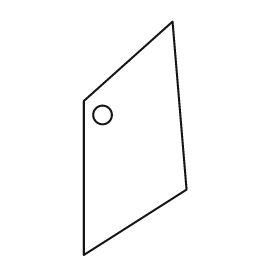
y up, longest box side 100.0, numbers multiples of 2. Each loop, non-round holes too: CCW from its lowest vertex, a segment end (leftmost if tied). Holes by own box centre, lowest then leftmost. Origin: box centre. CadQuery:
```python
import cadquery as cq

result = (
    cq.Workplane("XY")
    .moveTo(-22.0, -50.0)
    .lineTo(22.0, -22.0)
    .lineTo(16.0, 50.0)
    .lineTo(-22.0, 16.0)
    .close()
    .moveTo(-14.0, 10.0)
    .circle(4.0)
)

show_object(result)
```